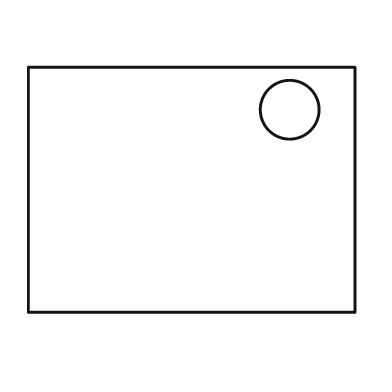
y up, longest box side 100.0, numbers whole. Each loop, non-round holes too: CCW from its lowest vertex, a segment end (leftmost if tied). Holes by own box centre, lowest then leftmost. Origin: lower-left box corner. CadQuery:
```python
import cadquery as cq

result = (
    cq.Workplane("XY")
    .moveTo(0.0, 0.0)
    .lineTo(100.0, 0.0)
    .lineTo(100.0, 75.0)
    .lineTo(0.0, 75.0)
    .close()
    .moveTo(80.0, 62.0)
    .circle(9.0)
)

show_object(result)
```